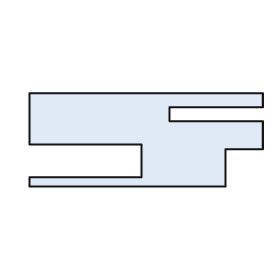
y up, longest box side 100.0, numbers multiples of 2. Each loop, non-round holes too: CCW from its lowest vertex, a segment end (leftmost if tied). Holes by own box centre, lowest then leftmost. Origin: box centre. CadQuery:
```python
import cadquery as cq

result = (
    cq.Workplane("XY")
    .moveTo(-50.0, -20.0)
    .lineTo(34.0, -20.0)
    .lineTo(34.0, -4.0)
    .lineTo(50.0, -4.0)
    .lineTo(50.0, 8.0)
    .lineTo(10.0, 8.0)
    .lineTo(10.0, 14.0)
    .lineTo(50.0, 14.0)
    .lineTo(50.0, 20.0)
    .lineTo(-50.0, 20.0)
    .lineTo(-50.0, -2.0)
    .lineTo(-2.0, -2.0)
    .lineTo(-2.0, -16.0)
    .lineTo(-50.0, -16.0)
    .close()
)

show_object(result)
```